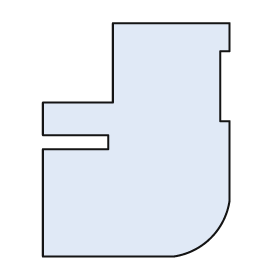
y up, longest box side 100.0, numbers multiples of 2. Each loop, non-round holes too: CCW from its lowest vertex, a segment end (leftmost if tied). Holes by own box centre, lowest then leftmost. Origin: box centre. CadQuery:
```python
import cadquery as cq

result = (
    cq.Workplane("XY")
    .moveTo(-40.0, -50.0)
    .lineTo(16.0, -50.0)
    .threePointArc((32.0, -42.0), (40.0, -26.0))
    .lineTo(40.0, 8.0)
    .lineTo(36.0, 8.0)
    .lineTo(36.0, 38.0)
    .lineTo(40.0, 38.0)
    .lineTo(40.0, 50.0)
    .lineTo(-10.0, 50.0)
    .lineTo(-10.0, 16.0)
    .lineTo(-40.0, 16.0)
    .lineTo(-40.0, 2.0)
    .lineTo(-12.0, 2.0)
    .lineTo(-12.0, -4.0)
    .lineTo(-40.0, -4.0)
    .close()
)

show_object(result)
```